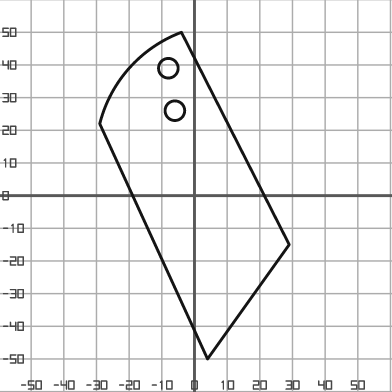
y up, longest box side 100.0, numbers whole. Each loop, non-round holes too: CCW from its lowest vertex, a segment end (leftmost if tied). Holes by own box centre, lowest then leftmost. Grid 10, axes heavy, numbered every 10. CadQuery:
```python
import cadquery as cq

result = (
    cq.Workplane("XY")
    .moveTo(4.0, -50.0)
    .lineTo(29.0, -15.0)
    .lineTo(-4.0, 50.0)
    .threePointArc((-20.0, 39.0), (-29.0, 22.0))
    .close()
    .moveTo(-6.0, 26.0)
    .circle(3.0)
    .moveTo(-8.0, 39.0)
    .circle(3.0)
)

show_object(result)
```